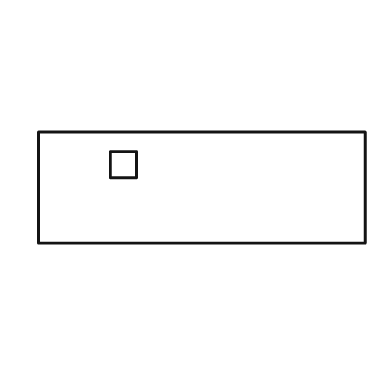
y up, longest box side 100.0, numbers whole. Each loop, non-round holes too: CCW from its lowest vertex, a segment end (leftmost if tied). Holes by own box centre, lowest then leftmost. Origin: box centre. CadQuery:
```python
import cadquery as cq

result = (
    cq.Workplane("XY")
    .moveTo(-50.0, -17.0)
    .lineTo(50.0, -17.0)
    .lineTo(50.0, 17.0)
    .lineTo(-50.0, 17.0)
    .close()
    .moveTo(-28.0, 3.0)
    .lineTo(-20.0, 3.0)
    .lineTo(-20.0, 11.0)
    .lineTo(-28.0, 11.0)
    .close()
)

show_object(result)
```